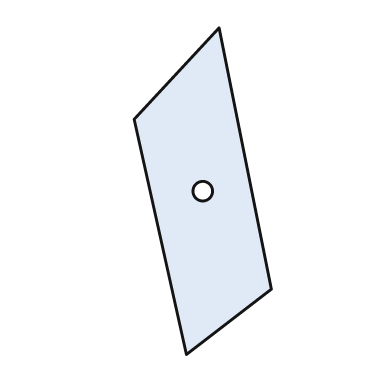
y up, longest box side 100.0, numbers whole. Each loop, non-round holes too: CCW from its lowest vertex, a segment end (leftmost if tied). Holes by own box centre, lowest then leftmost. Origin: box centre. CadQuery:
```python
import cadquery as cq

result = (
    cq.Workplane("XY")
    .moveTo(-5.0, -50.0)
    .lineTo(21.0, -30.0)
    .lineTo(5.0, 50.0)
    .lineTo(-21.0, 22.0)
    .close()
    .moveTo(0.0, 0.0)
    .circle(3.0)
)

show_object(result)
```